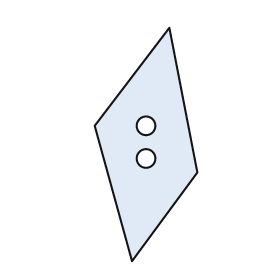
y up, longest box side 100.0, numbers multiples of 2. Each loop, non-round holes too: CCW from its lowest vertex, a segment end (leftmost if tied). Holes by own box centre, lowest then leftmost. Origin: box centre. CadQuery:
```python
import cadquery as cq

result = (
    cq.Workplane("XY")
    .moveTo(-6.0, -50.0)
    .lineTo(22.0, -12.0)
    .lineTo(10.0, 50.0)
    .lineTo(-22.0, 8.0)
    .close()
    .moveTo(0.0, -6.0)
    .circle(4.0)
    .moveTo(0.0, 8.0)
    .circle(4.0)
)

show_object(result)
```